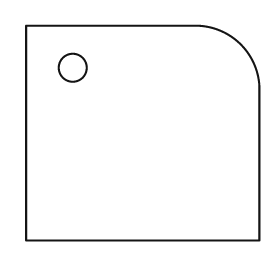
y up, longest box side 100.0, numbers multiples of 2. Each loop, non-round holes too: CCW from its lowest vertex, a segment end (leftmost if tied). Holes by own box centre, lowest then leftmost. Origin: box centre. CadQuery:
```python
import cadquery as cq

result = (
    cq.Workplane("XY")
    .moveTo(-50.0, -46.0)
    .lineTo(50.0, -46.0)
    .lineTo(50.0, 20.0)
    .threePointArc((42.0, 38.0), (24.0, 46.0))
    .lineTo(-50.0, 46.0)
    .close()
    .moveTo(-30.0, 28.0)
    .circle(6.0)
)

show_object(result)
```